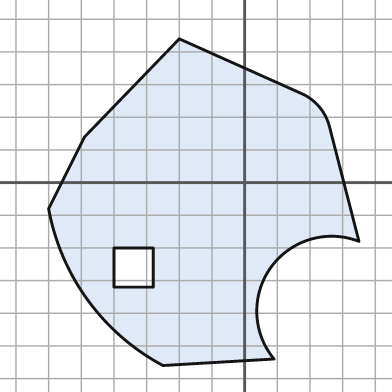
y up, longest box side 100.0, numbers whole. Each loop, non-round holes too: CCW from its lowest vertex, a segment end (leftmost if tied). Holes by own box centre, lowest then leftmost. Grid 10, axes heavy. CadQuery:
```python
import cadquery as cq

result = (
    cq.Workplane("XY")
    .moveTo(-25.0, -56.0)
    .lineTo(9.0, -54.0)
    .threePointArc((8.0, -26.0), (35.0, -18.0))
    .lineTo(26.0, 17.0)
    .threePointArc((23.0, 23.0), (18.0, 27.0))
    .lineTo(-20.0, 44.0)
    .lineTo(-49.0, 14.0)
    .lineTo(-60.0, -8.0)
    .threePointArc((-48.0, -36.0), (-25.0, -56.0))
    .close()
    .moveTo(-40.0, -32.0)
    .lineTo(-28.0, -32.0)
    .lineTo(-28.0, -20.0)
    .lineTo(-40.0, -20.0)
    .close()
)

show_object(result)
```